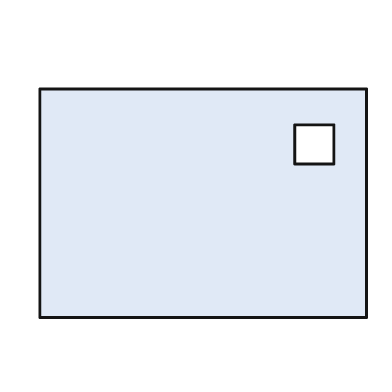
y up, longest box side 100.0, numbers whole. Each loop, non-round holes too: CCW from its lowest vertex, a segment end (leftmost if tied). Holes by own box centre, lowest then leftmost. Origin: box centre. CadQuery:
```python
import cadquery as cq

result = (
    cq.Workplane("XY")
    .moveTo(-50.0, -35.0)
    .lineTo(50.0, -35.0)
    .lineTo(50.0, 35.0)
    .lineTo(-50.0, 35.0)
    .close()
    .moveTo(28.0, 12.0)
    .lineTo(40.0, 12.0)
    .lineTo(40.0, 24.0)
    .lineTo(28.0, 24.0)
    .close()
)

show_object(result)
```